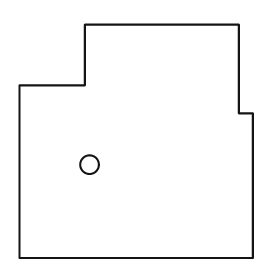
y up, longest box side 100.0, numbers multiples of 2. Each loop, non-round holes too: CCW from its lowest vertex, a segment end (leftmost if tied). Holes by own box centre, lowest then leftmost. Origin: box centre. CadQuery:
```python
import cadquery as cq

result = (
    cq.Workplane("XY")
    .moveTo(-50.0, -50.0)
    .lineTo(50.0, -50.0)
    .lineTo(50.0, 12.0)
    .lineTo(44.0, 12.0)
    .lineTo(44.0, 50.0)
    .lineTo(-22.0, 50.0)
    .lineTo(-22.0, 24.0)
    .lineTo(-50.0, 24.0)
    .close()
    .moveTo(-20.0, -10.0)
    .circle(4.0)
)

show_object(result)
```